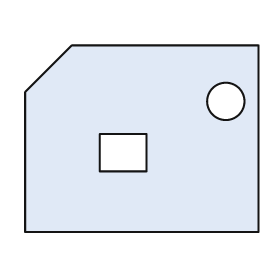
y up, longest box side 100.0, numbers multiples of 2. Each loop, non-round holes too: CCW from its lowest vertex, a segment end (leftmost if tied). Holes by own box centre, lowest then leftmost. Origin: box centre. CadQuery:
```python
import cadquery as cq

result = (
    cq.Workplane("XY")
    .moveTo(-50.0, -40.0)
    .lineTo(50.0, -40.0)
    .lineTo(50.0, 40.0)
    .lineTo(-30.0, 40.0)
    .lineTo(-50.0, 20.0)
    .close()
    .moveTo(-18.0, -14.0)
    .lineTo(2.0, -14.0)
    .lineTo(2.0, 2.0)
    .lineTo(-18.0, 2.0)
    .close()
    .moveTo(36.0, 16.0)
    .circle(8.0)
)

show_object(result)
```